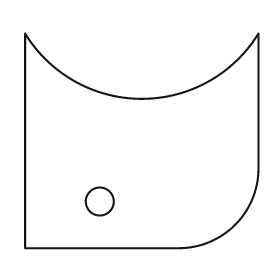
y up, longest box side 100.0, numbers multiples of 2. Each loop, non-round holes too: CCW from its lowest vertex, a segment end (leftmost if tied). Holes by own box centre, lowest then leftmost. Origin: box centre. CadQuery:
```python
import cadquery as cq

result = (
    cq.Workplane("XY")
    .moveTo(-50.0, -46.0)
    .lineTo(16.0, -46.0)
    .threePointArc((40.0, -36.0), (50.0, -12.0))
    .lineTo(50.0, 46.0)
    .threePointArc((0.0, 18.0), (-50.0, 46.0))
    .close()
    .moveTo(-18.0, -26.0)
    .circle(6.0)
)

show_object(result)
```